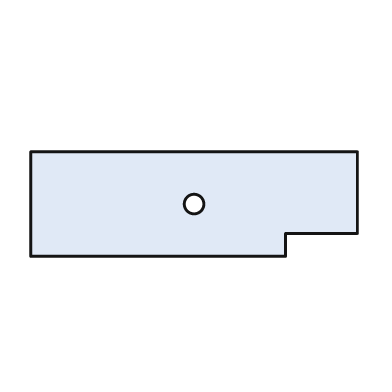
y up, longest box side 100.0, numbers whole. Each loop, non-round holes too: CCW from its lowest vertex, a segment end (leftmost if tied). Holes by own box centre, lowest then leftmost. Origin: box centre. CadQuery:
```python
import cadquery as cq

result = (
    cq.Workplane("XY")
    .moveTo(-50.0, -16.0)
    .lineTo(28.0, -16.0)
    .lineTo(28.0, -9.0)
    .lineTo(50.0, -9.0)
    .lineTo(50.0, 16.0)
    .lineTo(-50.0, 16.0)
    .close()
    .moveTo(0.0, 0.0)
    .circle(3.0)
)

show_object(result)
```